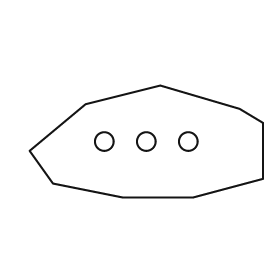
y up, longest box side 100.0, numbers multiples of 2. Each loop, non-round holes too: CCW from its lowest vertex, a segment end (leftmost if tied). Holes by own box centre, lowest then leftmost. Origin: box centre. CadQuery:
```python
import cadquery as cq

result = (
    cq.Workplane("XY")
    .moveTo(-10.0, -24.0)
    .lineTo(20.0, -24.0)
    .lineTo(50.0, -16.0)
    .lineTo(50.0, 8.0)
    .lineTo(40.0, 14.0)
    .lineTo(6.0, 24.0)
    .lineTo(-26.0, 16.0)
    .lineTo(-50.0, -4.0)
    .lineTo(-40.0, -18.0)
    .close()
    .moveTo(-18.0, 0.0)
    .circle(4.0)
    .moveTo(0.0, 0.0)
    .circle(4.0)
    .moveTo(18.0, 0.0)
    .circle(4.0)
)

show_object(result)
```